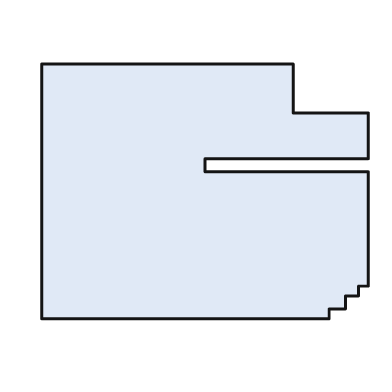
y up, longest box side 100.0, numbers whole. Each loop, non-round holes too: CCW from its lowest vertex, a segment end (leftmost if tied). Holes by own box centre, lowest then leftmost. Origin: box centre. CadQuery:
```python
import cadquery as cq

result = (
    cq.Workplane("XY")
    .moveTo(-50.0, -39.0)
    .lineTo(38.0, -39.0)
    .lineTo(38.0, -36.0)
    .lineTo(43.0, -36.0)
    .lineTo(43.0, -32.0)
    .lineTo(47.0, -32.0)
    .lineTo(47.0, -29.0)
    .lineTo(50.0, -29.0)
    .lineTo(50.0, 6.0)
    .lineTo(0.0, 6.0)
    .lineTo(0.0, 10.0)
    .lineTo(50.0, 10.0)
    .lineTo(50.0, 24.0)
    .lineTo(27.0, 24.0)
    .lineTo(27.0, 39.0)
    .lineTo(-50.0, 39.0)
    .close()
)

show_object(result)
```